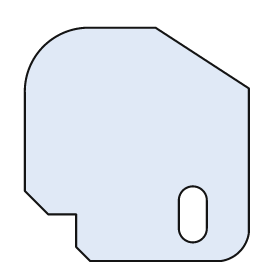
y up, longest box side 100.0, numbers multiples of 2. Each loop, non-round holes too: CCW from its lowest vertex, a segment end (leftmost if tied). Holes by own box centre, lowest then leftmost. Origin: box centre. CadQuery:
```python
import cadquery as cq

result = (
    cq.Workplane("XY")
    .moveTo(-20.0, -50.0)
    .lineTo(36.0, -50.0)
    .threePointArc((44.0, -46.0), (48.0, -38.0))
    .lineTo(48.0, 24.0)
    .lineTo(8.0, 50.0)
    .lineTo(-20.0, 50.0)
    .threePointArc((-40.0, 42.0), (-48.0, 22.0))
    .lineTo(-48.0, -20.0)
    .lineTo(-38.0, -30.0)
    .lineTo(-26.0, -30.0)
    .lineTo(-26.0, -44.0)
    .close()
    .moveTo(18.0, -36.0)
    .threePointArc((24.0, -42.0), (30.0, -36.0))
    .lineTo(30.0, -24.0)
    .threePointArc((24.0, -18.0), (18.0, -24.0))
    .close()
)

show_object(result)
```